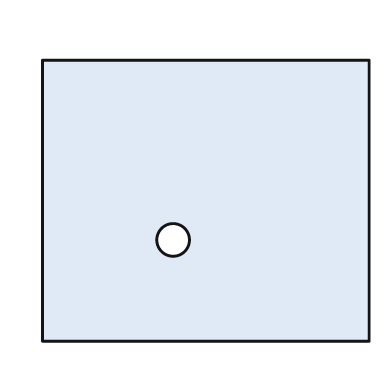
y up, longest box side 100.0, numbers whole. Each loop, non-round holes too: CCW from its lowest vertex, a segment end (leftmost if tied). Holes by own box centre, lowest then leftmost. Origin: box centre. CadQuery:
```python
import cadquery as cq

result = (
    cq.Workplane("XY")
    .moveTo(-50.0, -43.0)
    .lineTo(50.0, -43.0)
    .lineTo(50.0, 43.0)
    .lineTo(-50.0, 43.0)
    .close()
    .moveTo(-10.0, -12.0)
    .circle(5.0)
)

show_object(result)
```